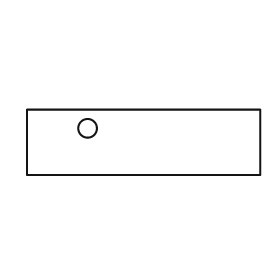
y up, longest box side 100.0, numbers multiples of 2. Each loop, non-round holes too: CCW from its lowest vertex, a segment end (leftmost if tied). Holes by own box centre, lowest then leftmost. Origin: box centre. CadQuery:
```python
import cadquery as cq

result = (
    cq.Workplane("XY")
    .moveTo(-50.0, -14.0)
    .lineTo(50.0, -14.0)
    .lineTo(50.0, 14.0)
    .lineTo(-50.0, 14.0)
    .close()
    .moveTo(-24.0, 6.0)
    .circle(4.0)
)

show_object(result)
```